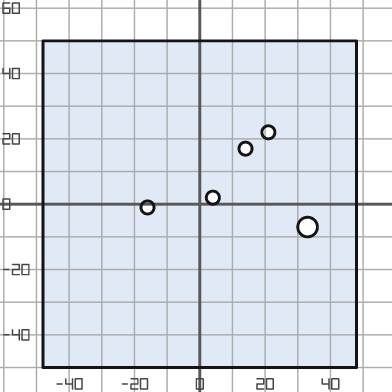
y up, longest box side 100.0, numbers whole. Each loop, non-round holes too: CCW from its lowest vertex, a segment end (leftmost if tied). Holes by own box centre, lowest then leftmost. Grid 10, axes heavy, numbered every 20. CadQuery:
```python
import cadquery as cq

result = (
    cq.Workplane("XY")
    .moveTo(-48.0, -50.0)
    .lineTo(48.0, -50.0)
    .lineTo(48.0, 50.0)
    .lineTo(-48.0, 50.0)
    .close()
    .moveTo(33.0, -7.0)
    .circle(3.0)
    .moveTo(-16.0, -1.0)
    .circle(2.0)
    .moveTo(4.0, 2.0)
    .circle(2.0)
    .moveTo(14.0, 17.0)
    .circle(2.0)
    .moveTo(21.0, 22.0)
    .circle(2.0)
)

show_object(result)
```